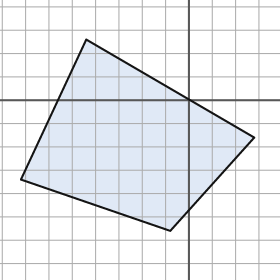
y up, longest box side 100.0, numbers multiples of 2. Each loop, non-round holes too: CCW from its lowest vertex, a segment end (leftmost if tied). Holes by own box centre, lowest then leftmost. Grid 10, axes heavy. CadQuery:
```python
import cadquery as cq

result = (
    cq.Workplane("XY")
    .moveTo(-8.0, -56.0)
    .lineTo(28.0, -16.0)
    .lineTo(-44.0, 26.0)
    .lineTo(-72.0, -34.0)
    .close()
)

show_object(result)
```